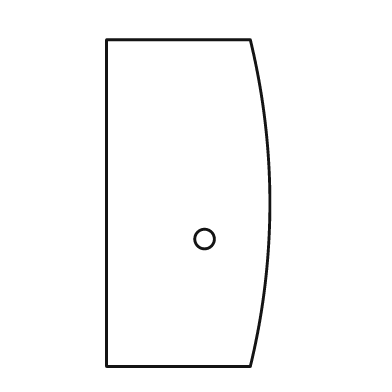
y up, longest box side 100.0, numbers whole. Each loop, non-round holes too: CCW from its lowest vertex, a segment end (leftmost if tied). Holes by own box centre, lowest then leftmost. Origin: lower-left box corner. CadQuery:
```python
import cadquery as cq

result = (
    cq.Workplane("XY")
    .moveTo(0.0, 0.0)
    .lineTo(44.0, 0.0)
    .threePointArc((50.0, 50.0), (44.0, 100.0))
    .lineTo(0.0, 100.0)
    .close()
    .moveTo(30.0, 39.0)
    .circle(3.0)
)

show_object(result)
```